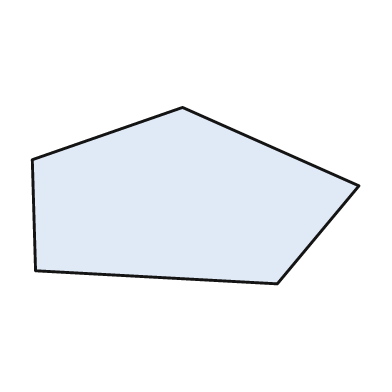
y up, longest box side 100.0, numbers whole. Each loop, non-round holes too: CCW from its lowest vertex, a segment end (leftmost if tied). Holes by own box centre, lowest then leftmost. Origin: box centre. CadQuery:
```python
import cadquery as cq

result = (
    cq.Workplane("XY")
    .moveTo(25.0, -27.0)
    .lineTo(50.0, 3.0)
    .lineTo(-4.0, 27.0)
    .lineTo(-50.0, 11.0)
    .lineTo(-49.0, -23.0)
    .close()
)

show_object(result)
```